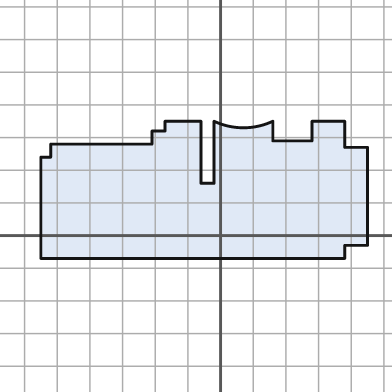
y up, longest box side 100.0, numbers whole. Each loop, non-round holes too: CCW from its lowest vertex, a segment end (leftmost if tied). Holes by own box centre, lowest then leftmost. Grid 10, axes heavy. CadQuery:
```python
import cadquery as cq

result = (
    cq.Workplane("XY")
    .moveTo(-55.0, -7.0)
    .lineTo(38.0, -7.0)
    .lineTo(38.0, -3.0)
    .lineTo(45.0, -3.0)
    .lineTo(45.0, 27.0)
    .lineTo(38.0, 27.0)
    .lineTo(38.0, 35.0)
    .lineTo(28.0, 35.0)
    .lineTo(28.0, 29.0)
    .lineTo(16.0, 29.0)
    .lineTo(16.0, 35.0)
    .threePointArc((7.0, 33.0), (-2.0, 35.0))
    .lineTo(-2.0, 16.0)
    .lineTo(-6.0, 16.0)
    .lineTo(-6.0, 35.0)
    .lineTo(-17.0, 35.0)
    .lineTo(-17.0, 32.0)
    .lineTo(-21.0, 32.0)
    .lineTo(-21.0, 28.0)
    .lineTo(-52.0, 28.0)
    .lineTo(-52.0, 24.0)
    .lineTo(-55.0, 24.0)
    .close()
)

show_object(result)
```